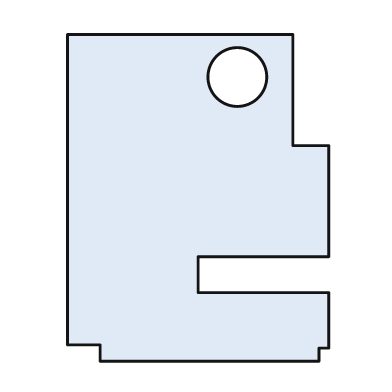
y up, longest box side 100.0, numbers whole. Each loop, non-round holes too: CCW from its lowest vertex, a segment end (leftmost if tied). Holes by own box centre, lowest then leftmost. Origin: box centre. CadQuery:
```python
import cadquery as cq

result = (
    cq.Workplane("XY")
    .moveTo(-30.0, -50.0)
    .lineTo(37.0, -50.0)
    .lineTo(37.0, -46.0)
    .lineTo(40.0, -46.0)
    .lineTo(40.0, -29.0)
    .lineTo(0.0, -29.0)
    .lineTo(0.0, -18.0)
    .lineTo(40.0, -18.0)
    .lineTo(40.0, 16.0)
    .lineTo(29.0, 16.0)
    .lineTo(29.0, 50.0)
    .lineTo(-40.0, 50.0)
    .lineTo(-40.0, -45.0)
    .lineTo(-30.0, -45.0)
    .close()
    .moveTo(12.0, 37.0)
    .circle(9.0)
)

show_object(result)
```